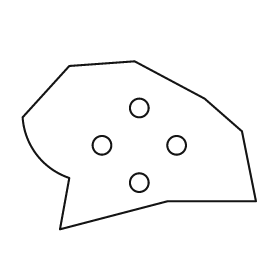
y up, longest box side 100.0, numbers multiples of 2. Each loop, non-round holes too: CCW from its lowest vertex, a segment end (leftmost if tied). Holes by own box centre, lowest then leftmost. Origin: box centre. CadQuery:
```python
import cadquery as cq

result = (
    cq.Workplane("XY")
    .moveTo(-34.0, -36.0)
    .lineTo(12.0, -24.0)
    .lineTo(50.0, -24.0)
    .lineTo(44.0, 6.0)
    .lineTo(28.0, 20.0)
    .lineTo(-2.0, 36.0)
    .lineTo(-30.0, 34.0)
    .lineTo(-50.0, 12.0)
    .threePointArc((-44.0, -4.0), (-30.0, -14.0))
    .close()
    .moveTo(0.0, -16.0)
    .circle(4.0)
    .moveTo(-16.0, 0.0)
    .circle(4.0)
    .moveTo(16.0, 0.0)
    .circle(4.0)
    .moveTo(0.0, 16.0)
    .circle(4.0)
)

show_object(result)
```